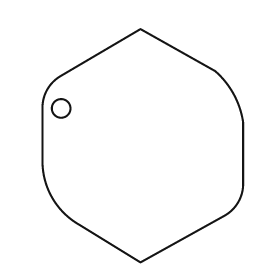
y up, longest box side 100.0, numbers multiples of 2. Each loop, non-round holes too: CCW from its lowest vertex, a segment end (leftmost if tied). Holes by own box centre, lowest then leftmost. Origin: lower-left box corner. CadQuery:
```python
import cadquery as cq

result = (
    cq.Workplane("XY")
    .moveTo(42.0, 0.0)
    .lineTo(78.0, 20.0)
    .threePointArc((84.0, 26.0), (86.0, 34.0))
    .lineTo(86.0, 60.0)
    .threePointArc((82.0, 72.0), (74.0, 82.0))
    .lineTo(42.0, 100.0)
    .lineTo(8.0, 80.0)
    .threePointArc((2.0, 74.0), (0.0, 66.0))
    .lineTo(0.0, 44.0)
    .threePointArc((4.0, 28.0), (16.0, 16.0))
    .close()
    .moveTo(8.0, 66.0)
    .circle(4.0)
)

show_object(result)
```